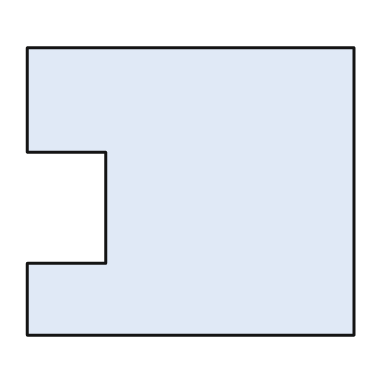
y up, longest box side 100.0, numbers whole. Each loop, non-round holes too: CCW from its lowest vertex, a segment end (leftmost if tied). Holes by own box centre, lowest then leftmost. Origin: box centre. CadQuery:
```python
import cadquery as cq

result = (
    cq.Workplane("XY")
    .moveTo(-50.0, -44.0)
    .lineTo(50.0, -44.0)
    .lineTo(50.0, 44.0)
    .lineTo(-50.0, 44.0)
    .lineTo(-50.0, 12.0)
    .lineTo(-26.0, 12.0)
    .lineTo(-26.0, -22.0)
    .lineTo(-50.0, -22.0)
    .close()
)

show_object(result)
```